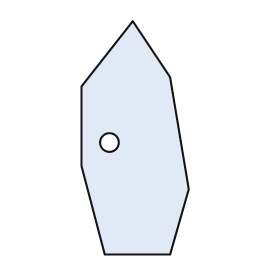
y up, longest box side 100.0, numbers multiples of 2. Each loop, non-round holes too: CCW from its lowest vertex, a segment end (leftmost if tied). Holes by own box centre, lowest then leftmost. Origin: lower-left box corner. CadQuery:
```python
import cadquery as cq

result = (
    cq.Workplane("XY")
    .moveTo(10.0, 0.0)
    .lineTo(38.0, 0.0)
    .lineTo(46.0, 28.0)
    .lineTo(38.0, 76.0)
    .lineTo(22.0, 100.0)
    .lineTo(0.0, 72.0)
    .lineTo(0.0, 38.0)
    .close()
    .moveTo(12.0, 48.0)
    .circle(4.0)
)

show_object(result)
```